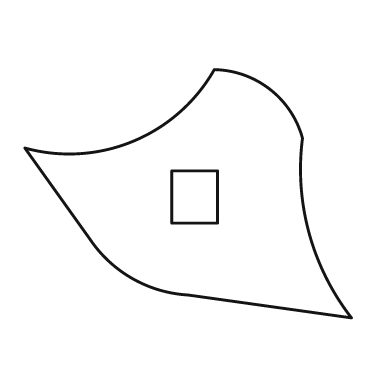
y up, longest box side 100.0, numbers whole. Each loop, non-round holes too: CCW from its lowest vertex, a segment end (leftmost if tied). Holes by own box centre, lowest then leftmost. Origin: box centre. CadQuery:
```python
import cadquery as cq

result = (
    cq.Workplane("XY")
    .moveTo(50.0, -38.0)
    .threePointArc((37.0, -12.0), (35.0, 17.0))
    .threePointArc((25.0, 32.0), (8.0, 38.0))
    .threePointArc((-17.0, 16.0), (-50.0, 14.0))
    .lineTo(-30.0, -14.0)
    .threePointArc((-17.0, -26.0), (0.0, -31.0))
    .close()
    .moveTo(-5.0, -9.0)
    .lineTo(9.0, -9.0)
    .lineTo(9.0, 7.0)
    .lineTo(-5.0, 7.0)
    .close()
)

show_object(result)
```